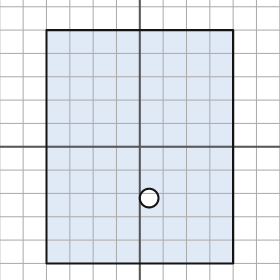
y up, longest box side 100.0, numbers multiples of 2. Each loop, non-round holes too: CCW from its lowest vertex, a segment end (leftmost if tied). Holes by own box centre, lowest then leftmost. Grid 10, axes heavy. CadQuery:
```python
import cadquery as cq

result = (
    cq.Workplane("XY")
    .moveTo(-40.0, -50.0)
    .lineTo(40.0, -50.0)
    .lineTo(40.0, 50.0)
    .lineTo(-40.0, 50.0)
    .close()
    .moveTo(4.0, -22.0)
    .circle(4.0)
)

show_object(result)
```